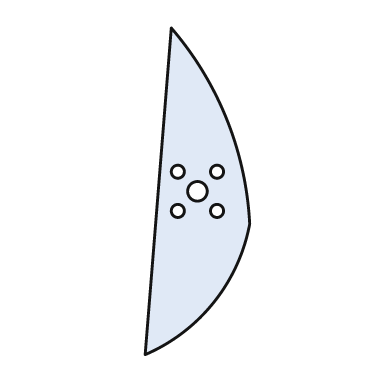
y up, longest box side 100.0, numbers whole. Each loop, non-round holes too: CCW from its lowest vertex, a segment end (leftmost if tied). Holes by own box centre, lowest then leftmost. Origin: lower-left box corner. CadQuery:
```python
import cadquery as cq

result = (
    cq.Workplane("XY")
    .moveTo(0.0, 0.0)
    .threePointArc((21.0, 16.0), (32.0, 40.0))
    .threePointArc((25.0, 72.0), (8.0, 100.0))
    .close()
    .moveTo(10.0, 44.0)
    .circle(2.0)
    .moveTo(22.0, 44.0)
    .circle(2.0)
    .moveTo(16.0, 50.0)
    .circle(3.0)
    .moveTo(10.0, 56.0)
    .circle(2.0)
    .moveTo(22.0, 56.0)
    .circle(2.0)
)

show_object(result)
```